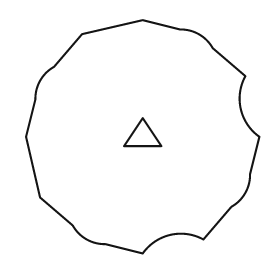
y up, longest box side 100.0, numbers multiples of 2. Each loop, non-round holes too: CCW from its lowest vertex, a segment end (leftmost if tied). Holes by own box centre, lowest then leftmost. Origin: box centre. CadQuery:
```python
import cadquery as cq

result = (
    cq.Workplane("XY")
    .moveTo(0.0, -50.0)
    .threePointArc((12.0, -42.0), (26.0, -44.0))
    .lineTo(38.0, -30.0)
    .threePointArc((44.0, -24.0), (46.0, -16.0))
    .lineTo(50.0, 0.0)
    .threePointArc((42.0, 12.0), (44.0, 26.0))
    .lineTo(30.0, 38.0)
    .threePointArc((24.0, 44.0), (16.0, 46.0))
    .lineTo(0.0, 50.0)
    .lineTo(-26.0, 44.0)
    .lineTo(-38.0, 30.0)
    .threePointArc((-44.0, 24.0), (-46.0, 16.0))
    .lineTo(-50.0, 0.0)
    .lineTo(-44.0, -26.0)
    .lineTo(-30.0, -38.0)
    .threePointArc((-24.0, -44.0), (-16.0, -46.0))
    .close()
    .moveTo(-8.0, -4.0)
    .lineTo(8.0, -4.0)
    .lineTo(0.0, 8.0)
    .close()
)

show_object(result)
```